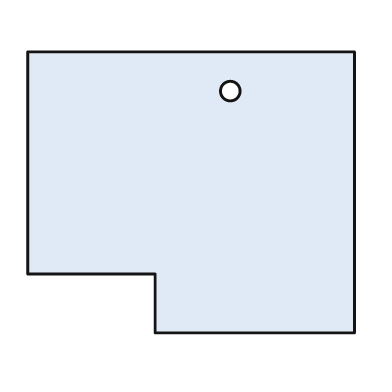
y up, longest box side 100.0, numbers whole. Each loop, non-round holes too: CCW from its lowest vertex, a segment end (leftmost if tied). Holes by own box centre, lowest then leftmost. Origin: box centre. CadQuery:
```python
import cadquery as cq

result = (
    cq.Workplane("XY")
    .moveTo(-11.0, -43.0)
    .lineTo(50.0, -43.0)
    .lineTo(50.0, 43.0)
    .lineTo(-50.0, 43.0)
    .lineTo(-50.0, -25.0)
    .lineTo(-11.0, -25.0)
    .close()
    .moveTo(12.0, 31.0)
    .circle(3.0)
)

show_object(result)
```